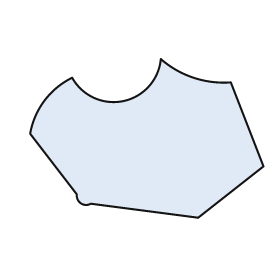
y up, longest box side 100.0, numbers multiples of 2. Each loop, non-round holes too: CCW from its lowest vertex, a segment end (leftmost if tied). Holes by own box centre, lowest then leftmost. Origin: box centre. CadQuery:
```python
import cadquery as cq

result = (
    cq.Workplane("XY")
    .moveTo(22.0, -34.0)
    .lineTo(50.0, -12.0)
    .lineTo(36.0, 24.0)
    .threePointArc((20.0, 26.0), (6.0, 34.0))
    .threePointArc((-10.0, 16.0), (-32.0, 26.0))
    .threePointArc((-44.0, 16.0), (-50.0, 2.0))
    .lineTo(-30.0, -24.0)
    .threePointArc((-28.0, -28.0), (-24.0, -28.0))
    .close()
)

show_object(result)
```